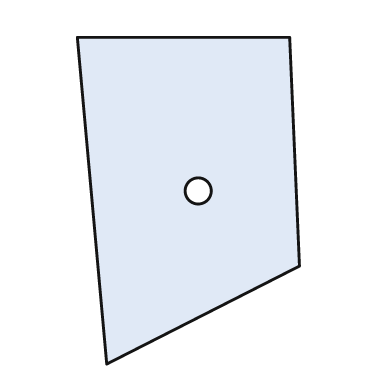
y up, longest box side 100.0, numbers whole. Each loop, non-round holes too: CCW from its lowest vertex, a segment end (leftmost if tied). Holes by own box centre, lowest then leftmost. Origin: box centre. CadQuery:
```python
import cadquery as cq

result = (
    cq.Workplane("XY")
    .moveTo(-25.0, -50.0)
    .lineTo(34.0, -20.0)
    .lineTo(31.0, 50.0)
    .lineTo(-34.0, 50.0)
    .close()
    .moveTo(3.0, 3.0)
    .circle(4.0)
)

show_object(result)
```